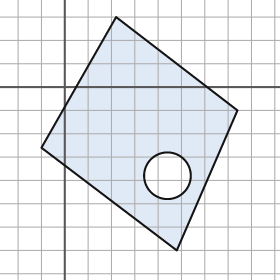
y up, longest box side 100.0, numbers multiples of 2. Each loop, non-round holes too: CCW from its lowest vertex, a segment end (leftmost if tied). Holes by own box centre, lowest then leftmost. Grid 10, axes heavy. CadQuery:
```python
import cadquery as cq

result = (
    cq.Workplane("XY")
    .moveTo(48.0, -70.0)
    .lineTo(74.0, -10.0)
    .lineTo(22.0, 30.0)
    .lineTo(-10.0, -26.0)
    .close()
    .moveTo(44.0, -38.0)
    .circle(10.0)
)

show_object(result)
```